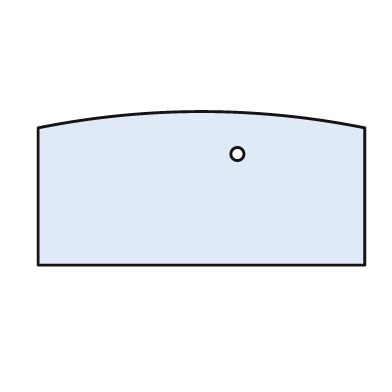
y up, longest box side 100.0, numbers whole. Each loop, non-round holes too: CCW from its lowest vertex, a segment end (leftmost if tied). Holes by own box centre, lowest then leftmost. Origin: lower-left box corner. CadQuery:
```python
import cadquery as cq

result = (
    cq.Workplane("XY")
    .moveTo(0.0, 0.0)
    .lineTo(100.0, 0.0)
    .lineTo(100.0, 42.0)
    .threePointArc((50.0, 47.0), (0.0, 42.0))
    .close()
    .moveTo(61.0, 34.0)
    .circle(2.0)
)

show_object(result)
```